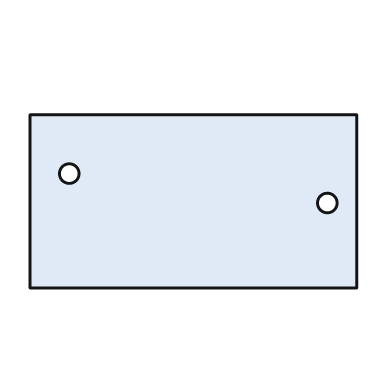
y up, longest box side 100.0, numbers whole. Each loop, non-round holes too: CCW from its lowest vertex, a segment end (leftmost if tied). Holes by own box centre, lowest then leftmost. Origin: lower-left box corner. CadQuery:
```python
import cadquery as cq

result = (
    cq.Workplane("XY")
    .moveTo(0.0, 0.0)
    .lineTo(100.0, 0.0)
    .lineTo(100.0, 53.0)
    .lineTo(0.0, 53.0)
    .close()
    .moveTo(91.0, 26.0)
    .circle(3.0)
    .moveTo(12.0, 35.0)
    .circle(3.0)
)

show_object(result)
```